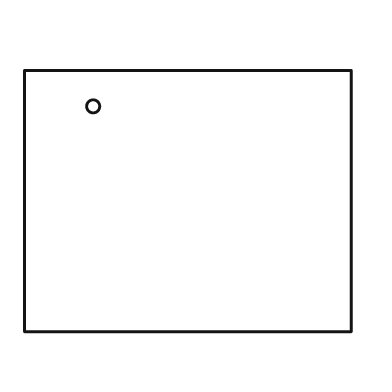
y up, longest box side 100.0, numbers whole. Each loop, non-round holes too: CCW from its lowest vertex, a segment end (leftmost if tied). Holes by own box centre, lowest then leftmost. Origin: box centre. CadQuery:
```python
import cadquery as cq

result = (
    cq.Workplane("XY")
    .moveTo(-50.0, -40.0)
    .lineTo(50.0, -40.0)
    .lineTo(50.0, 40.0)
    .lineTo(-50.0, 40.0)
    .close()
    .moveTo(-29.0, 29.0)
    .circle(2.0)
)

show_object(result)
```